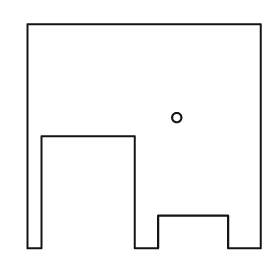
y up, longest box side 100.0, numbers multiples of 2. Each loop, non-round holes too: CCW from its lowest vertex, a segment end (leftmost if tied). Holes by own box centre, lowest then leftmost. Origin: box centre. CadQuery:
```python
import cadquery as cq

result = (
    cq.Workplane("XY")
    .moveTo(-50.0, -48.0)
    .lineTo(-44.0, -48.0)
    .lineTo(-44.0, 0.0)
    .lineTo(-4.0, 0.0)
    .lineTo(-4.0, -48.0)
    .lineTo(6.0, -48.0)
    .lineTo(6.0, -34.0)
    .lineTo(36.0, -34.0)
    .lineTo(36.0, -48.0)
    .lineTo(50.0, -48.0)
    .lineTo(50.0, 48.0)
    .lineTo(-50.0, 48.0)
    .close()
    .moveTo(14.0, 8.0)
    .circle(2.0)
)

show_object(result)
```